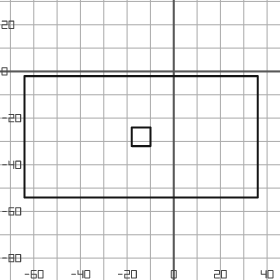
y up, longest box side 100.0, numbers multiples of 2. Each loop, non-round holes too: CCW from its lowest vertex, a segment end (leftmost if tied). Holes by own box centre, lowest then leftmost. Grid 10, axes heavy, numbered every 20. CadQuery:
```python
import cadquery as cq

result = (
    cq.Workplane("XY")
    .moveTo(-64.0, -54.0)
    .lineTo(36.0, -54.0)
    .lineTo(36.0, -2.0)
    .lineTo(-64.0, -2.0)
    .close()
    .moveTo(-18.0, -32.0)
    .lineTo(-10.0, -32.0)
    .lineTo(-10.0, -24.0)
    .lineTo(-18.0, -24.0)
    .close()
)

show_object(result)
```